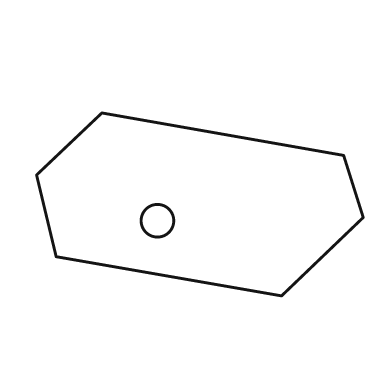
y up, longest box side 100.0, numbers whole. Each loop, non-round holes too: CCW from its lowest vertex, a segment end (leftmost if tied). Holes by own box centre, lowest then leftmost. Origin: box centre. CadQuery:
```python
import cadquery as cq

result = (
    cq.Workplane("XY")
    .moveTo(25.0, -28.0)
    .lineTo(50.0, -4.0)
    .lineTo(44.0, 15.0)
    .lineTo(-30.0, 28.0)
    .lineTo(-50.0, 9.0)
    .lineTo(-44.0, -16.0)
    .close()
    .moveTo(-13.0, -5.0)
    .circle(5.0)
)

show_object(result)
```